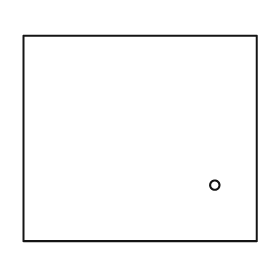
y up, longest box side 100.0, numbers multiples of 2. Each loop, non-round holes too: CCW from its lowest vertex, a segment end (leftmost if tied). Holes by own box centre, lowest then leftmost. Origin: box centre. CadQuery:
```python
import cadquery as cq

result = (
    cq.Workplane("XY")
    .moveTo(-50.0, -44.0)
    .lineTo(50.0, -44.0)
    .lineTo(50.0, 44.0)
    .lineTo(-50.0, 44.0)
    .close()
    .moveTo(32.0, -20.0)
    .circle(2.0)
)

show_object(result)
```